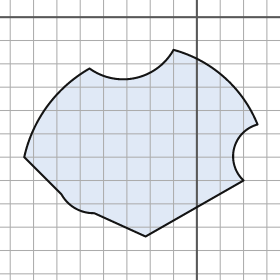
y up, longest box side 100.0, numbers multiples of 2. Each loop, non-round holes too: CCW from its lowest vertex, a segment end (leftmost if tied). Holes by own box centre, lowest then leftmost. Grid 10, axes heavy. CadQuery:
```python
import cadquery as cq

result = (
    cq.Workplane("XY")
    .moveTo(-22.0, -94.0)
    .lineTo(20.0, -70.0)
    .threePointArc((16.0, -56.0), (26.0, -46.0))
    .threePointArc((12.0, -26.0), (-10.0, -14.0))
    .threePointArc((-26.0, -26.0), (-46.0, -22.0))
    .threePointArc((-64.0, -38.0), (-74.0, -60.0))
    .lineTo(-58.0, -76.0)
    .threePointArc((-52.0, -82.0), (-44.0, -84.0))
    .close()
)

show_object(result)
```